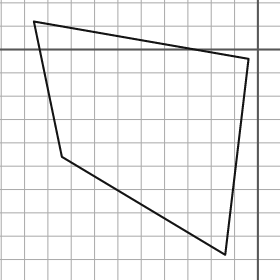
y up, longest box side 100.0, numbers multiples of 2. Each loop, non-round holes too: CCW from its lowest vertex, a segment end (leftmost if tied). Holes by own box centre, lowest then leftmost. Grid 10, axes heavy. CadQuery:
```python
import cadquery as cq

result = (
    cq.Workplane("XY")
    .moveTo(-14.0, -88.0)
    .lineTo(-4.0, -4.0)
    .lineTo(-96.0, 12.0)
    .lineTo(-84.0, -46.0)
    .close()
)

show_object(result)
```